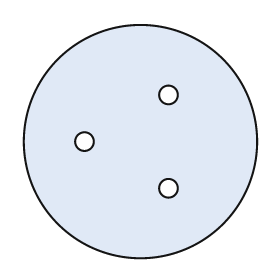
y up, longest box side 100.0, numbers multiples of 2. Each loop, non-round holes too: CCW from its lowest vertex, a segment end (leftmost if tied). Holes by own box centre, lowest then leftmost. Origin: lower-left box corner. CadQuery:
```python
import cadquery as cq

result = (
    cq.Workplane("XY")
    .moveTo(50.0, 50.0)
    .circle(50.0)
    .moveTo(62.0, 30.0)
    .circle(4.0)
    .moveTo(26.0, 50.0)
    .circle(4.0)
    .moveTo(62.0, 70.0)
    .circle(4.0)
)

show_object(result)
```